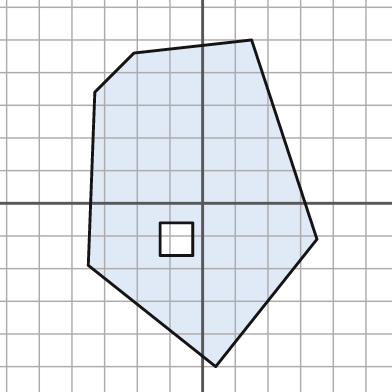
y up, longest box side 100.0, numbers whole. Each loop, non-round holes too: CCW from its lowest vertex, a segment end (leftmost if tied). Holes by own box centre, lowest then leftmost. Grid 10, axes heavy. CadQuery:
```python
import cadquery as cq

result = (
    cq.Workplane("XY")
    .moveTo(4.0, -50.0)
    .lineTo(35.0, -11.0)
    .lineTo(15.0, 50.0)
    .lineTo(-21.0, 46.0)
    .lineTo(-33.0, 34.0)
    .lineTo(-35.0, -19.0)
    .close()
    .moveTo(-13.0, -16.0)
    .lineTo(-3.0, -16.0)
    .lineTo(-3.0, -6.0)
    .lineTo(-13.0, -6.0)
    .close()
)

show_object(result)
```